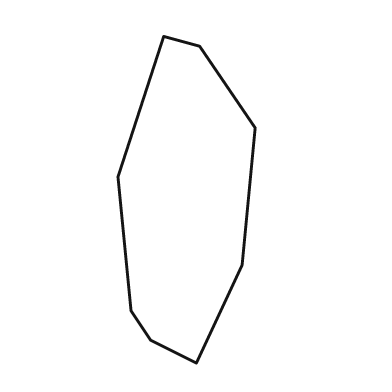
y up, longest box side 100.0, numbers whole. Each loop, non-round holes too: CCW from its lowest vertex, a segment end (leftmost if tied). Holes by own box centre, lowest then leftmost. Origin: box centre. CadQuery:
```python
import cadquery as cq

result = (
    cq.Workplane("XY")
    .moveTo(3.0, -50.0)
    .lineTo(17.0, -20.0)
    .lineTo(21.0, 22.0)
    .lineTo(4.0, 47.0)
    .lineTo(-7.0, 50.0)
    .lineTo(-21.0, 7.0)
    .lineTo(-17.0, -34.0)
    .lineTo(-11.0, -43.0)
    .close()
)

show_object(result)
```